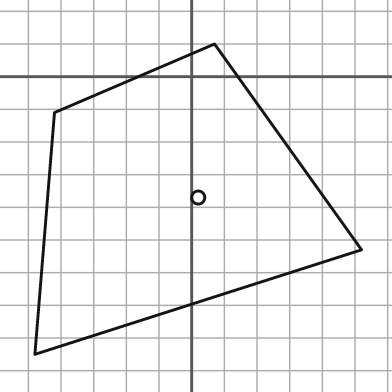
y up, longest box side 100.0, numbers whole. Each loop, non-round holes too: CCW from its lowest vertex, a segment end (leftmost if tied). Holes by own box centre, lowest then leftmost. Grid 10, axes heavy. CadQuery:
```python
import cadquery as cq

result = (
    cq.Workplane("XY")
    .moveTo(-48.0, -85.0)
    .lineTo(52.0, -53.0)
    .lineTo(7.0, 10.0)
    .lineTo(-42.0, -11.0)
    .close()
    .moveTo(2.0, -37.0)
    .circle(2.0)
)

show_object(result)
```